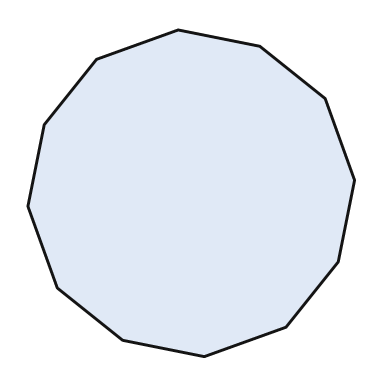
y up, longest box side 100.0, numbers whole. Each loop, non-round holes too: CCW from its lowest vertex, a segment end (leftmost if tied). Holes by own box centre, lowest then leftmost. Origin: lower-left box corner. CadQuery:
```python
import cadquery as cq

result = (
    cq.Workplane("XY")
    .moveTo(54.0, 0.0)
    .lineTo(79.0, 9.0)
    .lineTo(95.0, 29.0)
    .lineTo(100.0, 54.0)
    .lineTo(91.0, 79.0)
    .lineTo(71.0, 95.0)
    .lineTo(46.0, 100.0)
    .lineTo(21.0, 91.0)
    .lineTo(5.0, 71.0)
    .lineTo(0.0, 46.0)
    .lineTo(9.0, 21.0)
    .lineTo(29.0, 5.0)
    .close()
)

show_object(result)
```